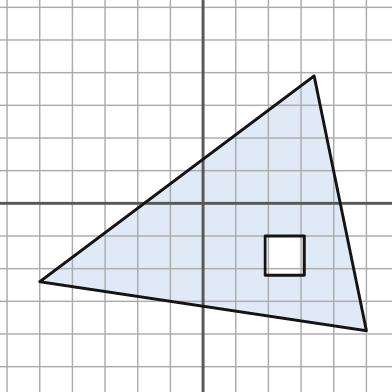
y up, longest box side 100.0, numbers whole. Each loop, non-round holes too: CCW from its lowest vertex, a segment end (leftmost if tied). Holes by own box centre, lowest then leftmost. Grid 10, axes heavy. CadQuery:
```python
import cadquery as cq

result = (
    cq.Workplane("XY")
    .moveTo(50.0, -39.0)
    .lineTo(34.0, 39.0)
    .lineTo(-50.0, -24.0)
    .close()
    .moveTo(19.0, -22.0)
    .lineTo(31.0, -22.0)
    .lineTo(31.0, -10.0)
    .lineTo(19.0, -10.0)
    .close()
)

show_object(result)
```